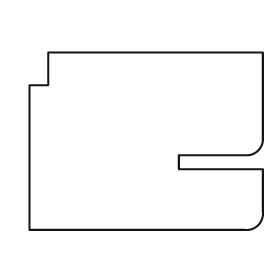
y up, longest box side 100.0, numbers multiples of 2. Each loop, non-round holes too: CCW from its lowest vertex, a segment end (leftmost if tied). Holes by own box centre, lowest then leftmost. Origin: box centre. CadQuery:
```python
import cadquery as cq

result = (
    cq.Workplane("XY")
    .moveTo(-50.0, -38.0)
    .lineTo(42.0, -38.0)
    .threePointArc((48.0, -36.0), (50.0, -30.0))
    .lineTo(50.0, -12.0)
    .lineTo(14.0, -12.0)
    .lineTo(14.0, -6.0)
    .lineTo(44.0, -6.0)
    .threePointArc((48.0, -4.0), (50.0, 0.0))
    .lineTo(50.0, 38.0)
    .lineTo(-42.0, 38.0)
    .lineTo(-42.0, 24.0)
    .lineTo(-50.0, 24.0)
    .close()
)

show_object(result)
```